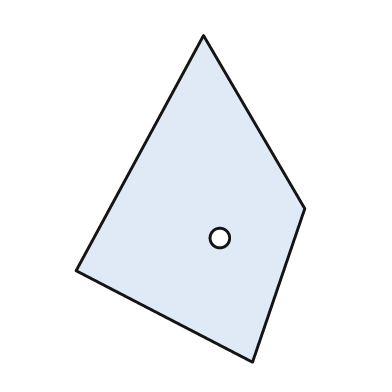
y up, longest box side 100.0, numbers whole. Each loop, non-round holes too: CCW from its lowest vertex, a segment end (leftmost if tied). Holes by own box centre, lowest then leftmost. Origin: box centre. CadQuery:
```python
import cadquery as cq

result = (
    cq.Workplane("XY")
    .moveTo(19.0, -50.0)
    .lineTo(35.0, -3.0)
    .lineTo(4.0, 50.0)
    .lineTo(-35.0, -22.0)
    .close()
    .moveTo(9.0, -12.0)
    .circle(3.0)
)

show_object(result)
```